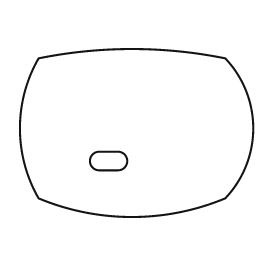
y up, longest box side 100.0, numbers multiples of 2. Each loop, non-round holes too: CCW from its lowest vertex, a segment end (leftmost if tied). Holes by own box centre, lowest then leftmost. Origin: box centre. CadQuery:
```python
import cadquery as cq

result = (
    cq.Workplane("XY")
    .moveTo(-42.0, -28.0)
    .threePointArc((-2.0, -36.0), (38.0, -28.0))
    .threePointArc((50.0, 2.0), (38.0, 32.0))
    .threePointArc((-2.0, 36.0), (-42.0, 32.0))
    .threePointArc((-50.0, 2.0), (-42.0, -28.0))
    .close()
    .moveTo(-16.0, -16.0)
    .lineTo(-8.0, -16.0)
    .threePointArc((-4.0, -12.0), (-8.0, -8.0))
    .lineTo(-16.0, -8.0)
    .threePointArc((-20.0, -12.0), (-16.0, -16.0))
    .close()
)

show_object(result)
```